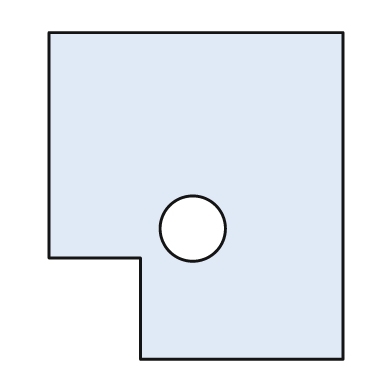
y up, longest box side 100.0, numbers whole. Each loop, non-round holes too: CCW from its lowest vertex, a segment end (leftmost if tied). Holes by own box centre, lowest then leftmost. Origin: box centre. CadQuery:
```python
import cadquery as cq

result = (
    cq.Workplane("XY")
    .moveTo(-17.0, -50.0)
    .lineTo(45.0, -50.0)
    .lineTo(45.0, 50.0)
    .lineTo(-45.0, 50.0)
    .lineTo(-45.0, -19.0)
    .lineTo(-17.0, -19.0)
    .close()
    .moveTo(-1.0, -10.0)
    .circle(10.0)
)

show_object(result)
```